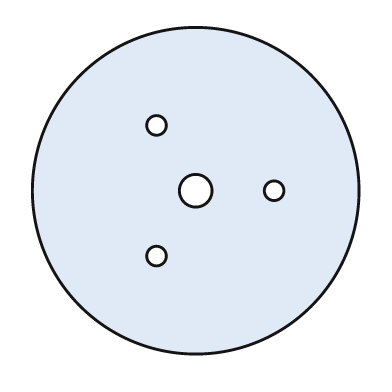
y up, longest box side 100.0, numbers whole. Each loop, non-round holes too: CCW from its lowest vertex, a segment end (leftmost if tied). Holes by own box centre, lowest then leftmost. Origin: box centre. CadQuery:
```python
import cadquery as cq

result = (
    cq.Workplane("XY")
    .moveTo(0.0, 0.0)
    .circle(50.0)
    .moveTo(-12.0, -20.0)
    .circle(3.0)
    .moveTo(0.0, 0.0)
    .circle(5.0)
    .moveTo(24.0, 0.0)
    .circle(3.0)
    .moveTo(-12.0, 20.0)
    .circle(3.0)
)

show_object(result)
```